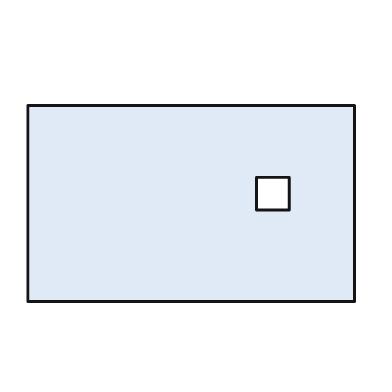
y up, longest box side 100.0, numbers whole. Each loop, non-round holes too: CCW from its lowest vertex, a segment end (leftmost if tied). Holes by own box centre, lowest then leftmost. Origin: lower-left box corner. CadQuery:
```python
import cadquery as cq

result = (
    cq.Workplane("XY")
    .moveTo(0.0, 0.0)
    .lineTo(100.0, 0.0)
    .lineTo(100.0, 60.0)
    .lineTo(0.0, 60.0)
    .close()
    .moveTo(70.0, 28.0)
    .lineTo(80.0, 28.0)
    .lineTo(80.0, 38.0)
    .lineTo(70.0, 38.0)
    .close()
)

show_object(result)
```